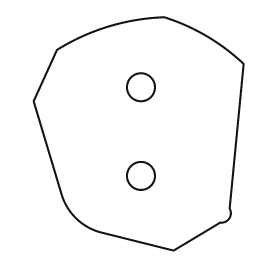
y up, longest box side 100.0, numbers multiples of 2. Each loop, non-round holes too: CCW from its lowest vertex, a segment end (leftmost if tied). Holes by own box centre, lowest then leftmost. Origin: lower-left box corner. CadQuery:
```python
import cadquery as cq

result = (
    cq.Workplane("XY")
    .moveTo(60.0, 0.0)
    .lineTo(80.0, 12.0)
    .threePointArc((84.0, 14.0), (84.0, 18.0))
    .lineTo(90.0, 80.0)
    .threePointArc((74.0, 92.0), (56.0, 100.0))
    .threePointArc((32.0, 96.0), (10.0, 86.0))
    .lineTo(0.0, 64.0)
    .lineTo(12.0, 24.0)
    .threePointArc((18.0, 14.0), (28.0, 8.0))
    .close()
    .moveTo(46.0, 32.0)
    .circle(6.0)
    .moveTo(46.0, 70.0)
    .circle(6.0)
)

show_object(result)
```